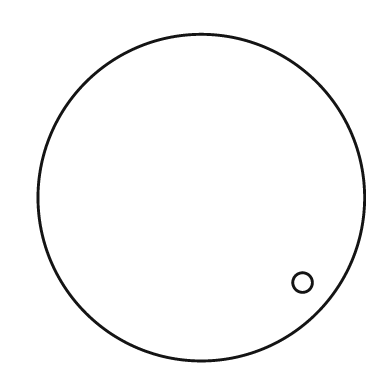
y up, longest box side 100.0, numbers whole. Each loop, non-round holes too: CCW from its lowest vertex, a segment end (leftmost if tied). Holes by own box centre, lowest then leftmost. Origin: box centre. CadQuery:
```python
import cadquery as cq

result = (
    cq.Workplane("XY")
    .moveTo(0.0, 0.0)
    .circle(50.0)
    .moveTo(31.0, -26.0)
    .circle(3.0)
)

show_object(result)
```